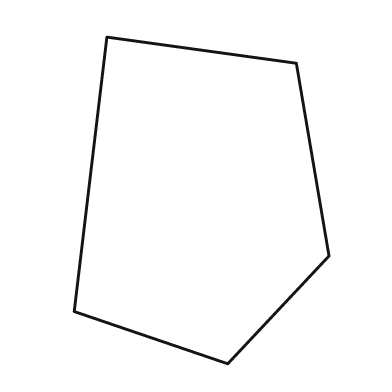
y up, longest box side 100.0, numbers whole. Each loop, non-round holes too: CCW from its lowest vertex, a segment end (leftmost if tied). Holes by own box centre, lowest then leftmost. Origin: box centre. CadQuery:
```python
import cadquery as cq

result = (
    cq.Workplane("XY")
    .moveTo(8.0, -50.0)
    .lineTo(39.0, -17.0)
    .lineTo(29.0, 42.0)
    .lineTo(-29.0, 50.0)
    .lineTo(-39.0, -34.0)
    .close()
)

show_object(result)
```